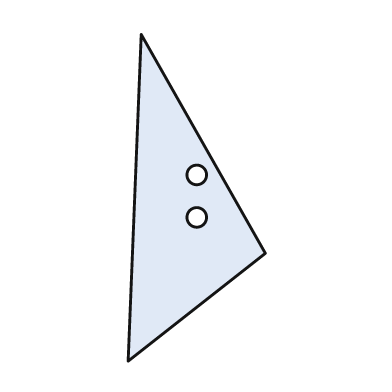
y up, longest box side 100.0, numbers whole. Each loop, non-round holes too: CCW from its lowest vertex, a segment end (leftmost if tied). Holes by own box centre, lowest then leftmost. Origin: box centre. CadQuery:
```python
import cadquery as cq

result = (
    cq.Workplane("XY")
    .moveTo(-21.0, -50.0)
    .lineTo(21.0, -17.0)
    .lineTo(-17.0, 50.0)
    .close()
    .moveTo(0.0, -6.0)
    .circle(3.0)
    .moveTo(0.0, 7.0)
    .circle(3.0)
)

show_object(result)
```